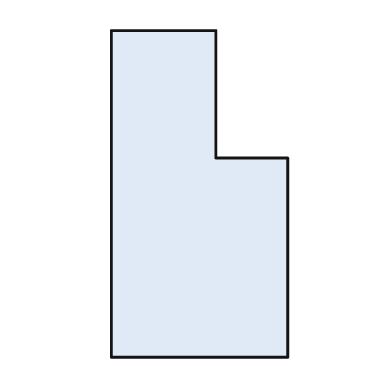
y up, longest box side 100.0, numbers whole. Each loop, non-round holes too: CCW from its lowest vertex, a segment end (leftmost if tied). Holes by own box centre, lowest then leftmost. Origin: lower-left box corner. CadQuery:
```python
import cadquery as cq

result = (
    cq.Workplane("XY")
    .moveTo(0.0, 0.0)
    .lineTo(54.0, 0.0)
    .lineTo(54.0, 61.0)
    .lineTo(32.0, 61.0)
    .lineTo(32.0, 100.0)
    .lineTo(0.0, 100.0)
    .close()
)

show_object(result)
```